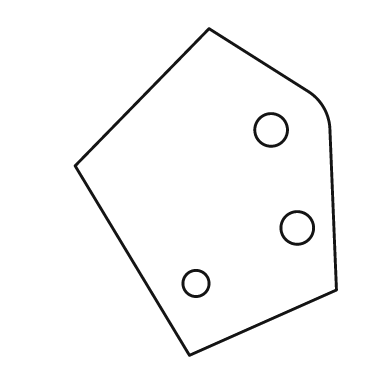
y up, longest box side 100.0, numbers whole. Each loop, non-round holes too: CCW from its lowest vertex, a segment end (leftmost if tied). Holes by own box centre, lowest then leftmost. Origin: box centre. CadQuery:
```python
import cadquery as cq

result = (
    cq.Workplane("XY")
    .moveTo(-5.0, -50.0)
    .lineTo(40.0, -30.0)
    .lineTo(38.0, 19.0)
    .threePointArc((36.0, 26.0), (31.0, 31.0))
    .lineTo(1.0, 50.0)
    .lineTo(-40.0, 8.0)
    .close()
    .moveTo(-3.0, -28.0)
    .circle(4.0)
    .moveTo(28.0, -11.0)
    .circle(5.0)
    .moveTo(20.0, 19.0)
    .circle(5.0)
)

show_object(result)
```